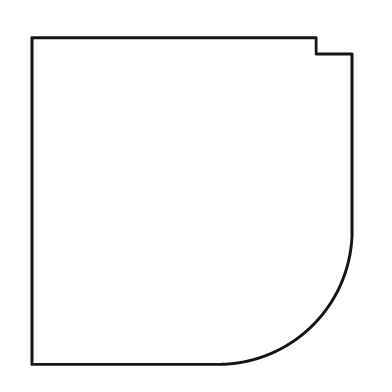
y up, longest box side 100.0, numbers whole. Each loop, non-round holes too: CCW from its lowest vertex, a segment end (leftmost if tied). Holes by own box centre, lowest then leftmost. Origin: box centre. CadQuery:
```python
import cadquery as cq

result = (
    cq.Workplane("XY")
    .moveTo(-49.0, -50.0)
    .lineTo(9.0, -50.0)
    .threePointArc((37.0, -38.0), (49.0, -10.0))
    .lineTo(49.0, 45.0)
    .lineTo(38.0, 45.0)
    .lineTo(38.0, 50.0)
    .lineTo(-49.0, 50.0)
    .close()
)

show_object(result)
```